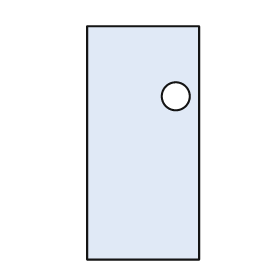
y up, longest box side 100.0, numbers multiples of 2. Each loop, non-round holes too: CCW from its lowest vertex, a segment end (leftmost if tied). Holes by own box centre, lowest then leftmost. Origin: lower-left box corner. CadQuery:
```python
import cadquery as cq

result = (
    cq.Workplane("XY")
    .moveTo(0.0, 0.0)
    .lineTo(48.0, 0.0)
    .lineTo(48.0, 100.0)
    .lineTo(0.0, 100.0)
    .close()
    .moveTo(38.0, 70.0)
    .circle(6.0)
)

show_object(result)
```